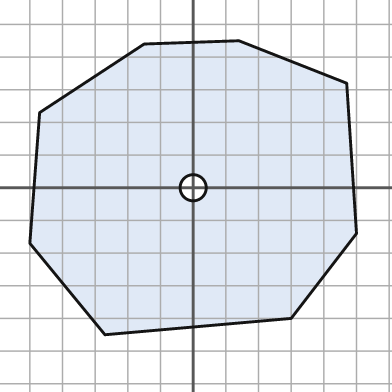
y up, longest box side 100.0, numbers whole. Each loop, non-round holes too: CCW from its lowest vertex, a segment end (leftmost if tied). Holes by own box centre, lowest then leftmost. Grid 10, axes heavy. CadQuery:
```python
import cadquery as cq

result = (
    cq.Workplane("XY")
    .moveTo(-27.0, -45.0)
    .lineTo(30.0, -40.0)
    .lineTo(50.0, -14.0)
    .lineTo(47.0, 32.0)
    .lineTo(14.0, 45.0)
    .lineTo(-15.0, 44.0)
    .lineTo(-47.0, 23.0)
    .lineTo(-50.0, -17.0)
    .close()
    .moveTo(0.0, 0.0)
    .circle(4.0)
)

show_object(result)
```